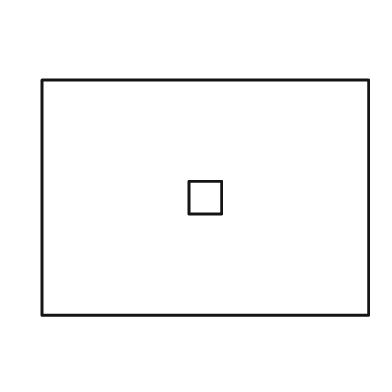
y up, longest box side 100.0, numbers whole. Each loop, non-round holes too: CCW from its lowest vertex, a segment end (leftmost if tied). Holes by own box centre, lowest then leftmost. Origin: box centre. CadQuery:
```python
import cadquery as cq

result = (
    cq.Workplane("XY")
    .moveTo(-50.0, -36.0)
    .lineTo(50.0, -36.0)
    .lineTo(50.0, 36.0)
    .lineTo(-50.0, 36.0)
    .close()
    .moveTo(-5.0, -5.0)
    .lineTo(5.0, -5.0)
    .lineTo(5.0, 5.0)
    .lineTo(-5.0, 5.0)
    .close()
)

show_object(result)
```